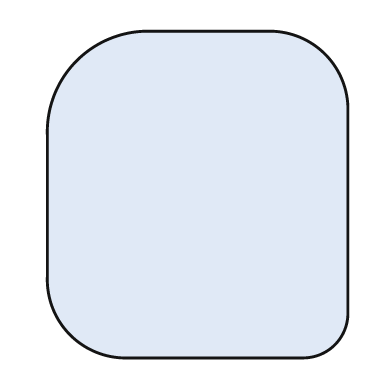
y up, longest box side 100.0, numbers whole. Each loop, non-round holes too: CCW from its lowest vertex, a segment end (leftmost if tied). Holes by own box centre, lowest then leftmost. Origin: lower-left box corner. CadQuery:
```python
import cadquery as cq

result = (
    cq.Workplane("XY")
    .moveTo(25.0, 0.0)
    .lineTo(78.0, 0.0)
    .threePointArc((88.0, 4.0), (92.0, 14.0))
    .lineTo(92.0, 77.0)
    .threePointArc((85.0, 93.0), (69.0, 100.0))
    .lineTo(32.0, 100.0)
    .threePointArc((9.0, 91.0), (0.0, 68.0))
    .lineTo(0.0, 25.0)
    .threePointArc((7.0, 7.0), (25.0, 0.0))
    .close()
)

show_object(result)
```